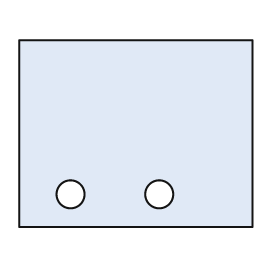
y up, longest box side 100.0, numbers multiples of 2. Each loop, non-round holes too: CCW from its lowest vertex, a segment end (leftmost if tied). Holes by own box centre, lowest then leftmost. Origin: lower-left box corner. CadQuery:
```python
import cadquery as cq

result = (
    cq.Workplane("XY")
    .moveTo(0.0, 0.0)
    .lineTo(100.0, 0.0)
    .lineTo(100.0, 80.0)
    .lineTo(0.0, 80.0)
    .close()
    .moveTo(22.0, 14.0)
    .circle(6.0)
    .moveTo(60.0, 14.0)
    .circle(6.0)
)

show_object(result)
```